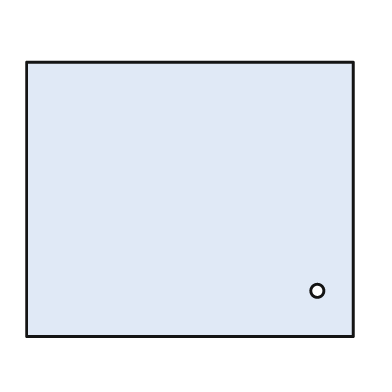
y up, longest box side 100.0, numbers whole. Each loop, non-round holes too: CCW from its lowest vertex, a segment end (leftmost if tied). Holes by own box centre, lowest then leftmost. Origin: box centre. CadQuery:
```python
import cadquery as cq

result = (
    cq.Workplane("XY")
    .moveTo(-50.0, -42.0)
    .lineTo(50.0, -42.0)
    .lineTo(50.0, 42.0)
    .lineTo(-50.0, 42.0)
    .close()
    .moveTo(39.0, -28.0)
    .circle(2.0)
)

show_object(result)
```